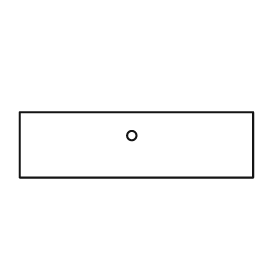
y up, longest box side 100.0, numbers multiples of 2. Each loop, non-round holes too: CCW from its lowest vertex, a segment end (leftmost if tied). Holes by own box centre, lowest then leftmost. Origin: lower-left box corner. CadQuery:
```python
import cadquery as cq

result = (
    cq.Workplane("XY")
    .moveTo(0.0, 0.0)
    .lineTo(100.0, 0.0)
    .lineTo(100.0, 28.0)
    .lineTo(0.0, 28.0)
    .close()
    .moveTo(48.0, 18.0)
    .circle(2.0)
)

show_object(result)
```